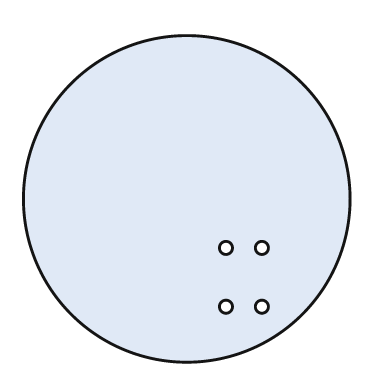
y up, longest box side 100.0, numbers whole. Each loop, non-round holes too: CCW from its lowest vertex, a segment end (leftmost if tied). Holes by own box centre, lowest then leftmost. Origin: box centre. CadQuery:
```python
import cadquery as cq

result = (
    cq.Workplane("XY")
    .moveTo(0.0, 0.0)
    .circle(50.0)
    .moveTo(12.0, -33.0)
    .circle(2.0)
    .moveTo(23.0, -33.0)
    .circle(2.0)
    .moveTo(12.0, -15.0)
    .circle(2.0)
    .moveTo(23.0, -15.0)
    .circle(2.0)
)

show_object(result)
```